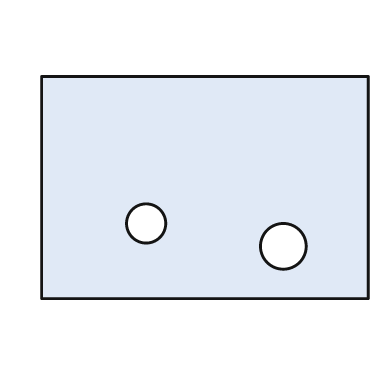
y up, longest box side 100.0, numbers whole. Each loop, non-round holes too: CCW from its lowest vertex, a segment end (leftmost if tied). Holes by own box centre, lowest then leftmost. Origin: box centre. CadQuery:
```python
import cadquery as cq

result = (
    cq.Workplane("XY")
    .moveTo(-50.0, -34.0)
    .lineTo(50.0, -34.0)
    .lineTo(50.0, 34.0)
    .lineTo(-50.0, 34.0)
    .close()
    .moveTo(24.0, -18.0)
    .circle(7.0)
    .moveTo(-18.0, -11.0)
    .circle(6.0)
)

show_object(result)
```